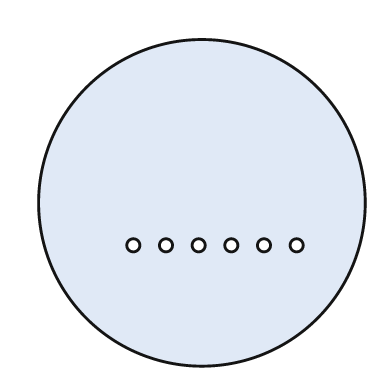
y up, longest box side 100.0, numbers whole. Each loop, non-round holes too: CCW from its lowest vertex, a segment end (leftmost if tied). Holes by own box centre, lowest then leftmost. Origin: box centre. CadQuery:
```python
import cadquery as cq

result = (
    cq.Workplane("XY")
    .moveTo(0.0, 0.0)
    .circle(50.0)
    .moveTo(-21.0, -13.0)
    .circle(2.0)
    .moveTo(-11.0, -13.0)
    .circle(2.0)
    .moveTo(-1.0, -13.0)
    .circle(2.0)
    .moveTo(9.0, -13.0)
    .circle(2.0)
    .moveTo(19.0, -13.0)
    .circle(2.0)
    .moveTo(29.0, -13.0)
    .circle(2.0)
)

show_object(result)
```